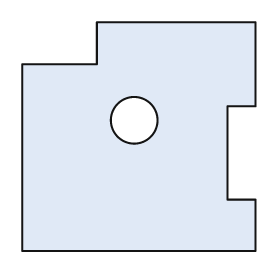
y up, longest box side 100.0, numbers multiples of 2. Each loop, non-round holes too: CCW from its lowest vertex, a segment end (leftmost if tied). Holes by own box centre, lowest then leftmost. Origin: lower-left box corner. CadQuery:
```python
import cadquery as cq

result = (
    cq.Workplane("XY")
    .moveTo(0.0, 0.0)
    .lineTo(100.0, 0.0)
    .lineTo(100.0, 22.0)
    .lineTo(88.0, 22.0)
    .lineTo(88.0, 62.0)
    .lineTo(100.0, 62.0)
    .lineTo(100.0, 98.0)
    .lineTo(32.0, 98.0)
    .lineTo(32.0, 80.0)
    .lineTo(0.0, 80.0)
    .close()
    .moveTo(48.0, 56.0)
    .circle(10.0)
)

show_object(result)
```